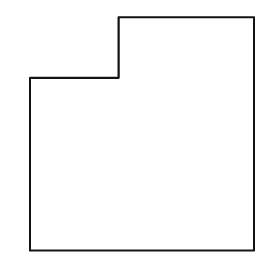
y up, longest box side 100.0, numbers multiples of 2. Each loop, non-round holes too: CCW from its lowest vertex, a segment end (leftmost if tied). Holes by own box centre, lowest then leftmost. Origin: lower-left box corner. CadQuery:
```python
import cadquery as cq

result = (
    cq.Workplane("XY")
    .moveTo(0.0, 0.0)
    .lineTo(96.0, 0.0)
    .lineTo(96.0, 100.0)
    .lineTo(38.0, 100.0)
    .lineTo(38.0, 74.0)
    .lineTo(0.0, 74.0)
    .close()
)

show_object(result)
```